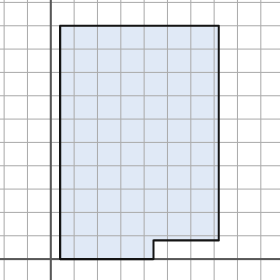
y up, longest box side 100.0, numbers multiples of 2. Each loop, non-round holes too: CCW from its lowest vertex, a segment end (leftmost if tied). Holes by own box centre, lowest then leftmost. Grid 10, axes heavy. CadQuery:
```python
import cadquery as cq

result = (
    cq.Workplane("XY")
    .moveTo(4.0, 0.0)
    .lineTo(44.0, 0.0)
    .lineTo(44.0, 8.0)
    .lineTo(72.0, 8.0)
    .lineTo(72.0, 100.0)
    .lineTo(4.0, 100.0)
    .close()
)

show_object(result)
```